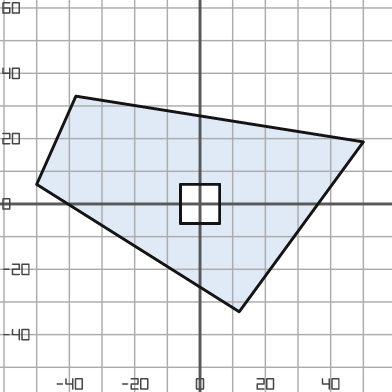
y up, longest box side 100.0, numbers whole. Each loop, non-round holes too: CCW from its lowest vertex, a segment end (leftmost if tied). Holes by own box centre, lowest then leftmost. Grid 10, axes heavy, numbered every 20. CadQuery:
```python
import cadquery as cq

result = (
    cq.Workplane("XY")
    .moveTo(12.0, -33.0)
    .lineTo(50.0, 19.0)
    .lineTo(-38.0, 33.0)
    .lineTo(-50.0, 6.0)
    .close()
    .moveTo(-6.0, -6.0)
    .lineTo(6.0, -6.0)
    .lineTo(6.0, 6.0)
    .lineTo(-6.0, 6.0)
    .close()
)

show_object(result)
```